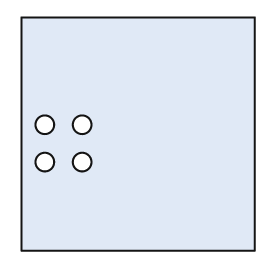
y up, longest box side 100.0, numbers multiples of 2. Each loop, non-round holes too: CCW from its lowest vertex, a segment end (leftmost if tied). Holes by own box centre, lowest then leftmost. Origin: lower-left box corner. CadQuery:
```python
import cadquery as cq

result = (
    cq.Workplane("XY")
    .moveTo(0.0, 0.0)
    .lineTo(100.0, 0.0)
    .lineTo(100.0, 100.0)
    .lineTo(0.0, 100.0)
    .close()
    .moveTo(10.0, 38.0)
    .circle(4.0)
    .moveTo(26.0, 38.0)
    .circle(4.0)
    .moveTo(10.0, 54.0)
    .circle(4.0)
    .moveTo(26.0, 54.0)
    .circle(4.0)
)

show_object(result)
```